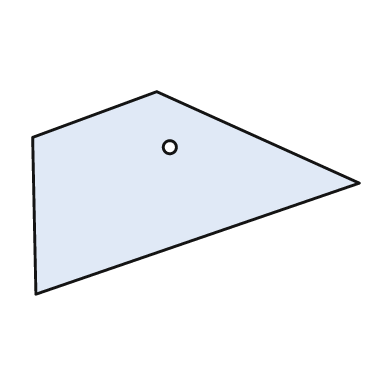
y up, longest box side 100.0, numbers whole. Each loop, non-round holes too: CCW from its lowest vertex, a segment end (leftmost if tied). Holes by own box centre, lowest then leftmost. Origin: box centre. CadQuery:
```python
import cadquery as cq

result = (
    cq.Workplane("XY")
    .moveTo(-49.0, -31.0)
    .lineTo(50.0, 3.0)
    .lineTo(-12.0, 31.0)
    .lineTo(-50.0, 17.0)
    .close()
    .moveTo(-8.0, 14.0)
    .circle(2.0)
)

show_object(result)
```